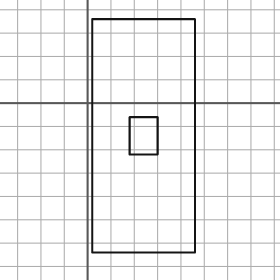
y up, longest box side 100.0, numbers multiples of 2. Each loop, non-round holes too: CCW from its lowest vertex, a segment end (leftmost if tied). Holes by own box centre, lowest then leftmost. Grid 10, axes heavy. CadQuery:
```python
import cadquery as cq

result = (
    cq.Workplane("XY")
    .moveTo(2.0, -64.0)
    .lineTo(46.0, -64.0)
    .lineTo(46.0, 36.0)
    .lineTo(2.0, 36.0)
    .close()
    .moveTo(18.0, -22.0)
    .lineTo(30.0, -22.0)
    .lineTo(30.0, -6.0)
    .lineTo(18.0, -6.0)
    .close()
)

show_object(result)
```